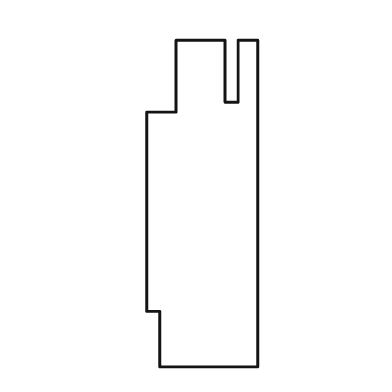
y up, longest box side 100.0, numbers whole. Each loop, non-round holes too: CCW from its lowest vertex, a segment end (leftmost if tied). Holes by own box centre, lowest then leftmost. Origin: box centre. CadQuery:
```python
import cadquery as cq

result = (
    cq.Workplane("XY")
    .moveTo(-13.0, -50.0)
    .lineTo(17.0, -50.0)
    .lineTo(17.0, 50.0)
    .lineTo(11.0, 50.0)
    .lineTo(11.0, 31.0)
    .lineTo(7.0, 31.0)
    .lineTo(7.0, 50.0)
    .lineTo(-8.0, 50.0)
    .lineTo(-8.0, 28.0)
    .lineTo(-17.0, 28.0)
    .lineTo(-17.0, -33.0)
    .lineTo(-13.0, -33.0)
    .close()
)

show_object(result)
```